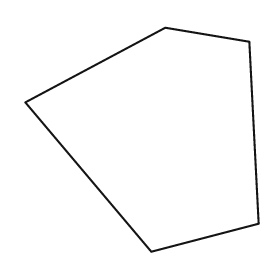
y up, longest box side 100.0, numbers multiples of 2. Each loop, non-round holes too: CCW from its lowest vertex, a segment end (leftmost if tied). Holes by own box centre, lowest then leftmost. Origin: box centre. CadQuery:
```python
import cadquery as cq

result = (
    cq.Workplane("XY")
    .moveTo(4.0, -48.0)
    .lineTo(50.0, -36.0)
    .lineTo(46.0, 42.0)
    .lineTo(10.0, 48.0)
    .lineTo(-50.0, 16.0)
    .close()
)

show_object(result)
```